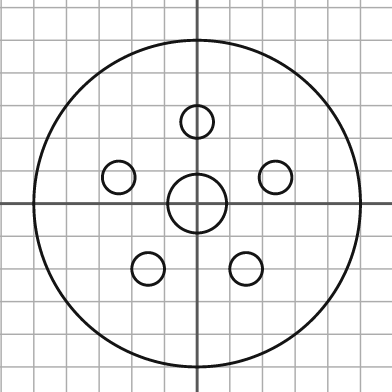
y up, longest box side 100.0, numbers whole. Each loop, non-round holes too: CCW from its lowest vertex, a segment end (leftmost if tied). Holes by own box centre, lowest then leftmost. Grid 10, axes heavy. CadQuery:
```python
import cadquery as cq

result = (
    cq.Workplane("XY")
    .moveTo(0.0, 0.0)
    .circle(50.0)
    .moveTo(-15.0, -20.0)
    .circle(5.0)
    .moveTo(15.0, -20.0)
    .circle(5.0)
    .moveTo(0.0, 0.0)
    .circle(9.0)
    .moveTo(-24.0, 8.0)
    .circle(5.0)
    .moveTo(24.0, 8.0)
    .circle(5.0)
    .moveTo(0.0, 25.0)
    .circle(5.0)
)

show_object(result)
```